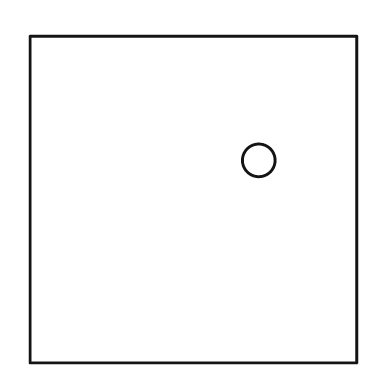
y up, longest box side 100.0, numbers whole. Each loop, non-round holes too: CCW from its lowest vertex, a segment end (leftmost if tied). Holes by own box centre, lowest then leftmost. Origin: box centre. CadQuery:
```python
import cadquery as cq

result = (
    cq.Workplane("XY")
    .moveTo(-50.0, -50.0)
    .lineTo(50.0, -50.0)
    .lineTo(50.0, 50.0)
    .lineTo(-50.0, 50.0)
    .close()
    .moveTo(20.0, 12.0)
    .circle(5.0)
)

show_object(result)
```